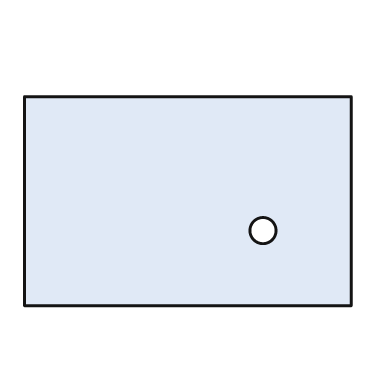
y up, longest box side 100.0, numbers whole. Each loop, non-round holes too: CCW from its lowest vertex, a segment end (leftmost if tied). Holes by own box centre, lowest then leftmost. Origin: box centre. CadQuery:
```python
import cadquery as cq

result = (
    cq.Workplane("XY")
    .moveTo(-50.0, -32.0)
    .lineTo(50.0, -32.0)
    .lineTo(50.0, 32.0)
    .lineTo(-50.0, 32.0)
    .close()
    .moveTo(23.0, -9.0)
    .circle(4.0)
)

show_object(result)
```